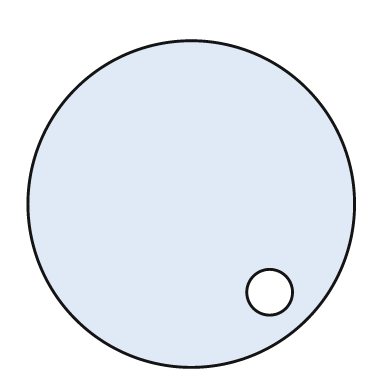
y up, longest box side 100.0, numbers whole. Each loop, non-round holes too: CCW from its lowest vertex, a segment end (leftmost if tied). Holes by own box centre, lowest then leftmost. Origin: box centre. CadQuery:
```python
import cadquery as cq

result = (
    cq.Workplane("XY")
    .moveTo(0.0, 0.0)
    .circle(50.0)
    .moveTo(24.0, -27.0)
    .circle(7.0)
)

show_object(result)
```